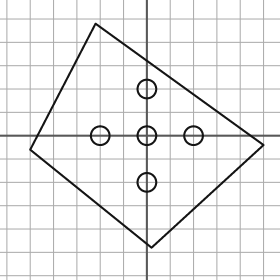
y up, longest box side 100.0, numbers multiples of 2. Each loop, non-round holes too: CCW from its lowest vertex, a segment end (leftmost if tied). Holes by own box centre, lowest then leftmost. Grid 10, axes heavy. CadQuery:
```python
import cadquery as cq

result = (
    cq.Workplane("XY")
    .moveTo(2.0, -48.0)
    .lineTo(50.0, -4.0)
    .lineTo(-22.0, 48.0)
    .lineTo(-50.0, -6.0)
    .close()
    .moveTo(0.0, -20.0)
    .circle(4.0)
    .moveTo(-20.0, 0.0)
    .circle(4.0)
    .moveTo(0.0, 0.0)
    .circle(4.0)
    .moveTo(20.0, 0.0)
    .circle(4.0)
    .moveTo(0.0, 20.0)
    .circle(4.0)
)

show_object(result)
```